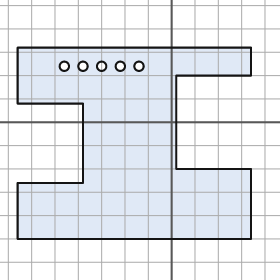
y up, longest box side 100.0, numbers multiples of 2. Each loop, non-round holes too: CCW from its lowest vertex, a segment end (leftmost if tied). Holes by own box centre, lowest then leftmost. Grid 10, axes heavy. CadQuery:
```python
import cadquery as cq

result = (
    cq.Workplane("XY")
    .moveTo(-66.0, -50.0)
    .lineTo(34.0, -50.0)
    .lineTo(34.0, -20.0)
    .lineTo(2.0, -20.0)
    .lineTo(2.0, 20.0)
    .lineTo(34.0, 20.0)
    .lineTo(34.0, 32.0)
    .lineTo(-66.0, 32.0)
    .lineTo(-66.0, 8.0)
    .lineTo(-38.0, 8.0)
    .lineTo(-38.0, -26.0)
    .lineTo(-66.0, -26.0)
    .close()
    .moveTo(-46.0, 24.0)
    .circle(2.0)
    .moveTo(-38.0, 24.0)
    .circle(2.0)
    .moveTo(-30.0, 24.0)
    .circle(2.0)
    .moveTo(-22.0, 24.0)
    .circle(2.0)
    .moveTo(-14.0, 24.0)
    .circle(2.0)
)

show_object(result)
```